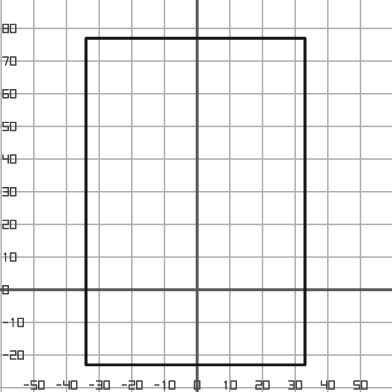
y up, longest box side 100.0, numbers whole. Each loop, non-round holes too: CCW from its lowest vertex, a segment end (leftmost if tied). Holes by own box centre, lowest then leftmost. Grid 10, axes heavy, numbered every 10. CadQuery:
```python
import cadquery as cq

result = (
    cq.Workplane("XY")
    .moveTo(-34.0, -23.0)
    .lineTo(33.0, -23.0)
    .lineTo(33.0, 77.0)
    .lineTo(-34.0, 77.0)
    .close()
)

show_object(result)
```